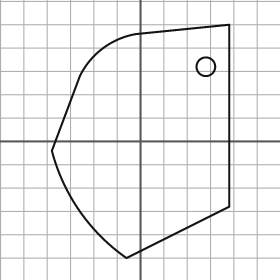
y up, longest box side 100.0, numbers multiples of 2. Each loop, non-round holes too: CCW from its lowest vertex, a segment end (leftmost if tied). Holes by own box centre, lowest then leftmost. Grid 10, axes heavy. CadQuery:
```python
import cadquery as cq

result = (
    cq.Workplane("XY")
    .moveTo(-6.0, -50.0)
    .lineTo(38.0, -28.0)
    .lineTo(38.0, 50.0)
    .lineTo(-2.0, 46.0)
    .threePointArc((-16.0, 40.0), (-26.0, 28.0))
    .lineTo(-38.0, -4.0)
    .threePointArc((-26.0, -30.0), (-6.0, -50.0))
    .close()
    .moveTo(28.0, 32.0)
    .circle(4.0)
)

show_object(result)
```